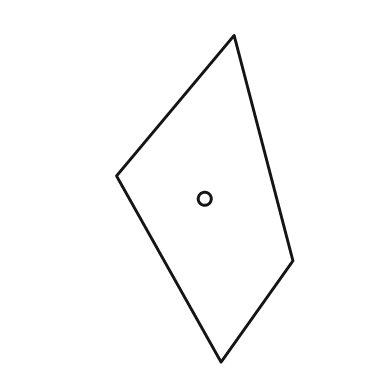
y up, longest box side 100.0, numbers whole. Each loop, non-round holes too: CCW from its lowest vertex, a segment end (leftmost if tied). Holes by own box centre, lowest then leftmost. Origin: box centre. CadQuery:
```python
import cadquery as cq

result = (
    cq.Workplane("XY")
    .moveTo(5.0, -50.0)
    .lineTo(27.0, -19.0)
    .lineTo(9.0, 50.0)
    .lineTo(-27.0, 7.0)
    .close()
    .moveTo(0.0, 0.0)
    .circle(2.0)
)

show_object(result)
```